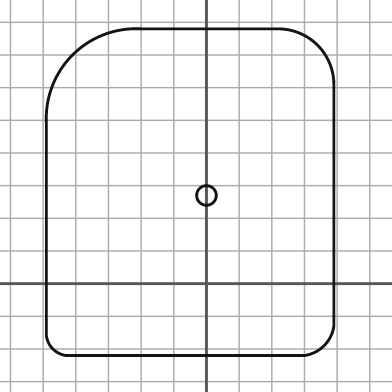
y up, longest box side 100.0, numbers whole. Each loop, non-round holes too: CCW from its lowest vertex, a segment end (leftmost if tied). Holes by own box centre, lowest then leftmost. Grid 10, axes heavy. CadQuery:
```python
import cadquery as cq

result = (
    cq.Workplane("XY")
    .moveTo(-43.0, -22.0)
    .lineTo(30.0, -22.0)
    .threePointArc((36.0, -19.0), (39.0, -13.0))
    .lineTo(39.0, 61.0)
    .threePointArc((34.0, 73.0), (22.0, 78.0))
    .lineTo(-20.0, 78.0)
    .threePointArc((-41.0, 70.0), (-49.0, 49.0))
    .lineTo(-49.0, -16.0)
    .threePointArc((-47.0, -20.0), (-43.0, -22.0))
    .close()
    .moveTo(0.0, 27.0)
    .circle(3.0)
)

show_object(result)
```